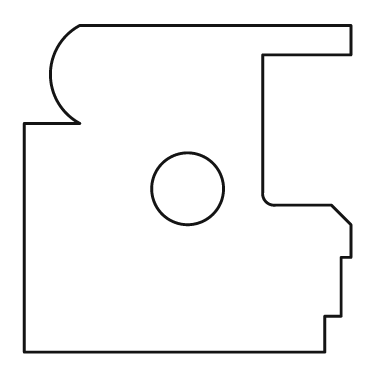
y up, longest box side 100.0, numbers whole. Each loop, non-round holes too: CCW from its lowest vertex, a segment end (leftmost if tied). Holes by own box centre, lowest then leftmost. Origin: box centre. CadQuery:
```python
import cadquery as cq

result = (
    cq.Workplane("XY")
    .moveTo(-50.0, -50.0)
    .lineTo(42.0, -50.0)
    .lineTo(42.0, -39.0)
    .lineTo(47.0, -39.0)
    .lineTo(47.0, -21.0)
    .lineTo(50.0, -21.0)
    .lineTo(50.0, -11.0)
    .lineTo(44.0, -5.0)
    .lineTo(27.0, -5.0)
    .threePointArc((24.0, -4.0), (23.0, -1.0))
    .lineTo(23.0, 41.0)
    .lineTo(50.0, 41.0)
    .lineTo(50.0, 50.0)
    .lineTo(-33.0, 50.0)
    .threePointArc((-42.0, 35.0), (-33.0, 20.0))
    .lineTo(-50.0, 20.0)
    .close()
    .moveTo(0.0, 0.0)
    .circle(11.0)
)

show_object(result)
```